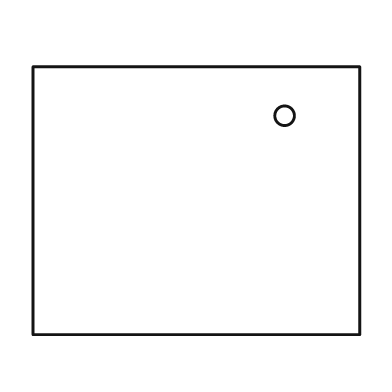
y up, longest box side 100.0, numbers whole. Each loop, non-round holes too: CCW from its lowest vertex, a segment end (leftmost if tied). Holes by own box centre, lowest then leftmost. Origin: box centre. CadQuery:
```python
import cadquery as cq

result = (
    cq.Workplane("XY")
    .moveTo(-50.0, -41.0)
    .lineTo(50.0, -41.0)
    .lineTo(50.0, 41.0)
    .lineTo(-50.0, 41.0)
    .close()
    .moveTo(27.0, 26.0)
    .circle(3.0)
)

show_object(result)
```